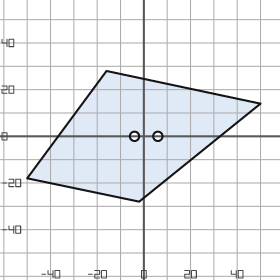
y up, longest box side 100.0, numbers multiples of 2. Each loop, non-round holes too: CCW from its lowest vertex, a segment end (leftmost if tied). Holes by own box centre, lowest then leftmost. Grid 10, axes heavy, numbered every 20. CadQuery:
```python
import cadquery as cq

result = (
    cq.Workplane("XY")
    .moveTo(-2.0, -28.0)
    .lineTo(50.0, 14.0)
    .lineTo(-16.0, 28.0)
    .lineTo(-50.0, -18.0)
    .close()
    .moveTo(-4.0, 0.0)
    .circle(2.0)
    .moveTo(6.0, 0.0)
    .circle(2.0)
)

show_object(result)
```